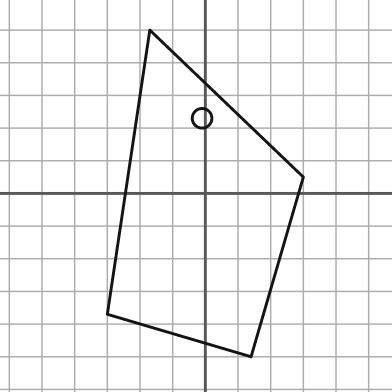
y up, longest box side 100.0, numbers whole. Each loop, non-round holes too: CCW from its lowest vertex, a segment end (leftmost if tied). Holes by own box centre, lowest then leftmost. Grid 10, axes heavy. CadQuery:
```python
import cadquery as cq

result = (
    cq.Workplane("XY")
    .moveTo(14.0, -50.0)
    .lineTo(30.0, 5.0)
    .lineTo(-17.0, 50.0)
    .lineTo(-30.0, -37.0)
    .close()
    .moveTo(-1.0, 23.0)
    .circle(3.0)
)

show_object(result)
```